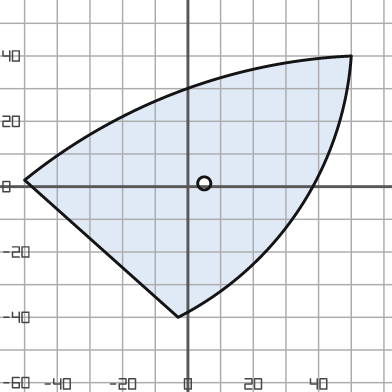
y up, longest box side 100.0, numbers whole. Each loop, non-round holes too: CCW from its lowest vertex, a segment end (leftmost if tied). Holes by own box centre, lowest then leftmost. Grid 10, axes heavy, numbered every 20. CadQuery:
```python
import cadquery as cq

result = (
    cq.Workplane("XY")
    .moveTo(-3.0, -40.0)
    .threePointArc((34.0, -7.0), (50.0, 40.0))
    .threePointArc((-3.0, 29.0), (-50.0, 2.0))
    .close()
    .moveTo(5.0, 1.0)
    .circle(2.0)
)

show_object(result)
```